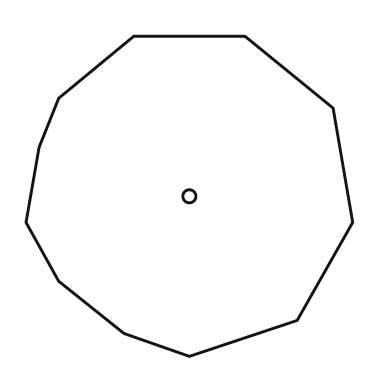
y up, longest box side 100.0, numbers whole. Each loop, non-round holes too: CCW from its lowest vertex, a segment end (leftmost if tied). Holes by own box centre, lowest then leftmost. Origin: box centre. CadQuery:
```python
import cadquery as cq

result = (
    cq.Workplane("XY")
    .moveTo(0.0, -49.0)
    .lineTo(33.0, -38.0)
    .lineTo(50.0, -8.0)
    .lineTo(44.0, 27.0)
    .lineTo(17.0, 49.0)
    .lineTo(-17.0, 49.0)
    .lineTo(-40.0, 30.0)
    .lineTo(-46.0, 15.0)
    .lineTo(-50.0, -8.0)
    .lineTo(-40.0, -26.0)
    .lineTo(-20.0, -42.0)
    .close()
    .moveTo(0.0, 0.0)
    .circle(2.0)
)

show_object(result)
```